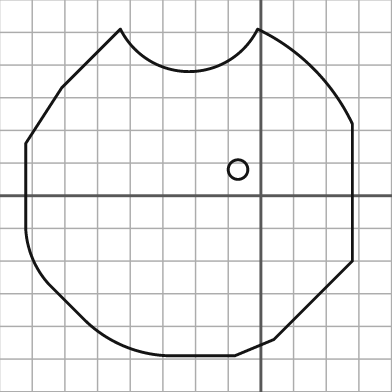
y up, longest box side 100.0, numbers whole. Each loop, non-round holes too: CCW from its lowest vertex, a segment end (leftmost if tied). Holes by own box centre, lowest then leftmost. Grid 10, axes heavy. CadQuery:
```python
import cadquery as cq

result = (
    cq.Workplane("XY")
    .moveTo(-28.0, -49.0)
    .lineTo(-8.0, -49.0)
    .lineTo(4.0, -44.0)
    .lineTo(28.0, -20.0)
    .lineTo(28.0, 22.0)
    .threePointArc((16.0, 39.0), (-1.0, 51.0))
    .threePointArc((-22.0, 38.0), (-43.0, 51.0))
    .lineTo(-61.0, 33.0)
    .lineTo(-72.0, 16.0)
    .lineTo(-72.0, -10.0)
    .threePointArc((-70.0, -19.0), (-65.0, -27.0))
    .lineTo(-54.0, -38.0)
    .threePointArc((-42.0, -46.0), (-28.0, -49.0))
    .close()
    .moveTo(-7.0, 8.0)
    .circle(3.0)
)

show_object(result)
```